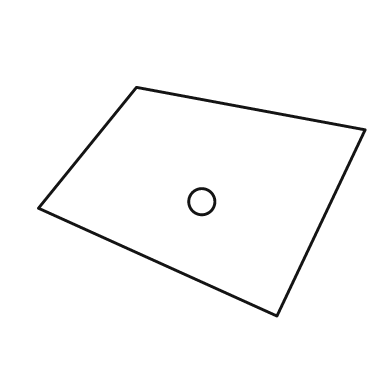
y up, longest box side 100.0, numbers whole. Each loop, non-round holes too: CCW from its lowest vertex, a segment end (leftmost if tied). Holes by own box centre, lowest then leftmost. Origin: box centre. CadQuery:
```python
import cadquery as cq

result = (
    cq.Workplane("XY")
    .moveTo(23.0, -35.0)
    .lineTo(50.0, 22.0)
    .lineTo(-20.0, 35.0)
    .lineTo(-50.0, -2.0)
    .close()
    .moveTo(0.0, 0.0)
    .circle(4.0)
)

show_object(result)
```